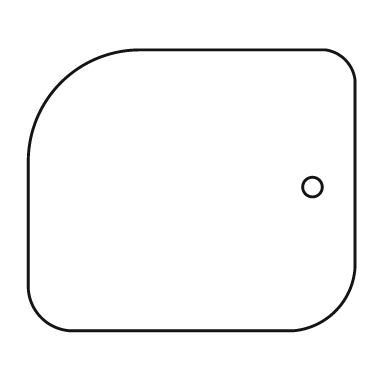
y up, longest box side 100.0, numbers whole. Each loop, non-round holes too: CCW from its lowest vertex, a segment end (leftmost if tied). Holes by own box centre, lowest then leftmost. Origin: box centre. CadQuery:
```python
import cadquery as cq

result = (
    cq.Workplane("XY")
    .moveTo(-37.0, -43.0)
    .lineTo(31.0, -43.0)
    .threePointArc((44.0, -37.0), (50.0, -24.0))
    .lineTo(50.0, 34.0)
    .threePointArc((47.0, 40.0), (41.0, 43.0))
    .lineTo(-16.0, 43.0)
    .threePointArc((-40.0, 33.0), (-50.0, 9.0))
    .lineTo(-50.0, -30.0)
    .threePointArc((-46.0, -39.0), (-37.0, -43.0))
    .close()
    .moveTo(37.0, 1.0)
    .circle(3.0)
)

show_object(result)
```